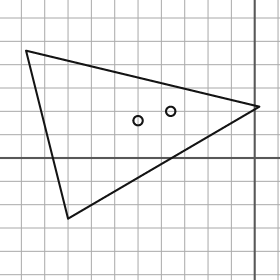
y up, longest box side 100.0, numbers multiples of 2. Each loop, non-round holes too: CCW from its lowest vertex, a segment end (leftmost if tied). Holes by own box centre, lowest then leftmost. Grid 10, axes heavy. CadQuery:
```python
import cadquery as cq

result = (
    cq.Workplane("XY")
    .moveTo(-80.0, -26.0)
    .lineTo(2.0, 22.0)
    .lineTo(-98.0, 46.0)
    .close()
    .moveTo(-50.0, 16.0)
    .circle(2.0)
    .moveTo(-36.0, 20.0)
    .circle(2.0)
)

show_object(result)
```